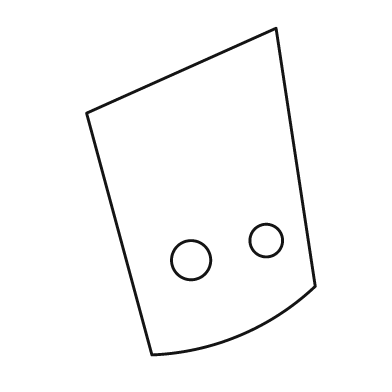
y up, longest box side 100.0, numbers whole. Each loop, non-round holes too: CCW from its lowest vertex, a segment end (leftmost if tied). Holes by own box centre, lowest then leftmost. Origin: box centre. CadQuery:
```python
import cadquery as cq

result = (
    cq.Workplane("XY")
    .moveTo(-15.0, -50.0)
    .threePointArc((12.0, -44.0), (35.0, -29.0))
    .lineTo(23.0, 50.0)
    .lineTo(-35.0, 24.0)
    .close()
    .moveTo(-3.0, -21.0)
    .circle(6.0)
    .moveTo(20.0, -15.0)
    .circle(5.0)
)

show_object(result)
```